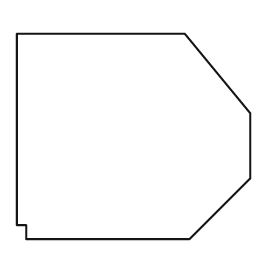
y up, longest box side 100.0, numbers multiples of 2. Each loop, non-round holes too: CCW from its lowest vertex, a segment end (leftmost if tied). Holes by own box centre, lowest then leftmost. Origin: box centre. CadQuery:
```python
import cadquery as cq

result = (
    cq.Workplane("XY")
    .moveTo(-46.0, -44.0)
    .lineTo(24.0, -44.0)
    .lineTo(50.0, -18.0)
    .lineTo(50.0, 10.0)
    .lineTo(22.0, 44.0)
    .lineTo(-50.0, 44.0)
    .lineTo(-50.0, -38.0)
    .lineTo(-46.0, -38.0)
    .close()
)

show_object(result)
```